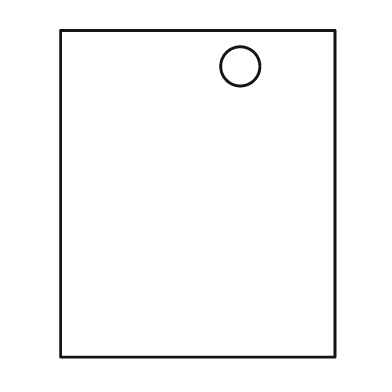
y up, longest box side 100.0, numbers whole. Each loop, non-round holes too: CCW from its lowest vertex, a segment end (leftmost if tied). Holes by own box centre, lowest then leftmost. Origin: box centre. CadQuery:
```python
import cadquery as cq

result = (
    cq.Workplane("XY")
    .moveTo(-42.0, -50.0)
    .lineTo(42.0, -50.0)
    .lineTo(42.0, 50.0)
    .lineTo(-42.0, 50.0)
    .close()
    .moveTo(13.0, 39.0)
    .circle(6.0)
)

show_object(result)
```